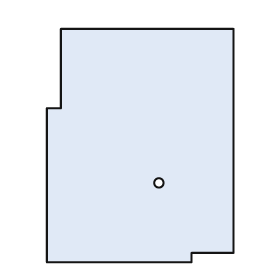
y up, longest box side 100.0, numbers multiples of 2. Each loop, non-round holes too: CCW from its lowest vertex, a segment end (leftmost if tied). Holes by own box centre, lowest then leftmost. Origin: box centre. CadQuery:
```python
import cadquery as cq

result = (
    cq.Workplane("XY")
    .moveTo(-40.0, -50.0)
    .lineTo(22.0, -50.0)
    .lineTo(22.0, -46.0)
    .lineTo(40.0, -46.0)
    .lineTo(40.0, 50.0)
    .lineTo(-34.0, 50.0)
    .lineTo(-34.0, 16.0)
    .lineTo(-40.0, 16.0)
    .close()
    .moveTo(8.0, -16.0)
    .circle(2.0)
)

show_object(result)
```